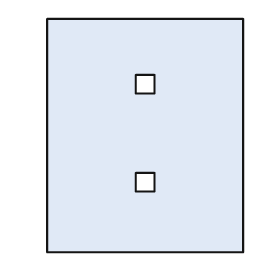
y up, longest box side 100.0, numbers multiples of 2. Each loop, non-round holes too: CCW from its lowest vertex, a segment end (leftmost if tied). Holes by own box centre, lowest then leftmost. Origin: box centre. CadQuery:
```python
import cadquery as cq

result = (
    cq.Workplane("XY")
    .moveTo(-42.0, -50.0)
    .lineTo(42.0, -50.0)
    .lineTo(42.0, 50.0)
    .lineTo(-42.0, 50.0)
    .close()
    .moveTo(-4.0, -24.0)
    .lineTo(4.0, -24.0)
    .lineTo(4.0, -16.0)
    .lineTo(-4.0, -16.0)
    .close()
    .moveTo(-4.0, 18.0)
    .lineTo(4.0, 18.0)
    .lineTo(4.0, 26.0)
    .lineTo(-4.0, 26.0)
    .close()
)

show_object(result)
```